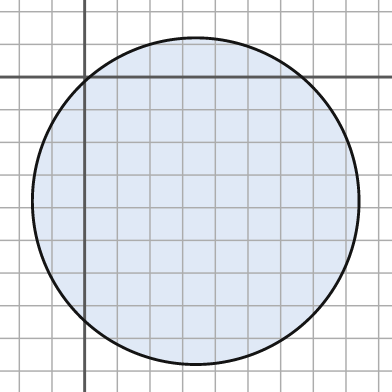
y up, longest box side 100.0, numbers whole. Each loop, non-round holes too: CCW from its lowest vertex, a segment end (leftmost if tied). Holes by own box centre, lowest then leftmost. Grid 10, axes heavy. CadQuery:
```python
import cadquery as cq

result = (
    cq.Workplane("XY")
    .moveTo(34.0, -38.0)
    .circle(50.0)
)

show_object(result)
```